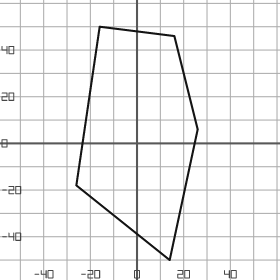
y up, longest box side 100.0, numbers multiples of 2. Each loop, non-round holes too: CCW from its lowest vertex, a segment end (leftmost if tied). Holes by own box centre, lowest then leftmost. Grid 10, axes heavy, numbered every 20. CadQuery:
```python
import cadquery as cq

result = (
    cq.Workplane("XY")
    .moveTo(14.0, -50.0)
    .lineTo(26.0, 6.0)
    .lineTo(16.0, 46.0)
    .lineTo(-16.0, 50.0)
    .lineTo(-26.0, -18.0)
    .close()
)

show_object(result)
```